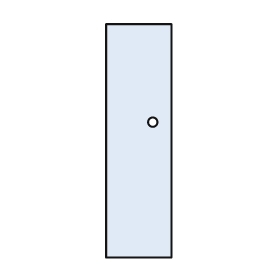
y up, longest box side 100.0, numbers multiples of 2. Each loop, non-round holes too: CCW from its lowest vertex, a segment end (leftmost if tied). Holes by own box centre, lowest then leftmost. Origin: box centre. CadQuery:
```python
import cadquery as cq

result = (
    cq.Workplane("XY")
    .moveTo(-14.0, -50.0)
    .lineTo(14.0, -50.0)
    .lineTo(14.0, 50.0)
    .lineTo(-14.0, 50.0)
    .close()
    .moveTo(6.0, 8.0)
    .circle(2.0)
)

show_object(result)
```